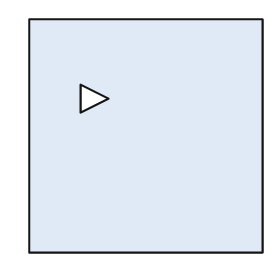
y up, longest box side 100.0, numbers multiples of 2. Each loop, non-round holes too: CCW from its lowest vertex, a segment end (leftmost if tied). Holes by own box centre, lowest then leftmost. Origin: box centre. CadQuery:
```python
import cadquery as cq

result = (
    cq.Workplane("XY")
    .moveTo(-50.0, -50.0)
    .lineTo(50.0, -50.0)
    .lineTo(50.0, 50.0)
    .lineTo(-50.0, 50.0)
    .close()
    .moveTo(-28.0, 10.0)
    .lineTo(-16.0, 16.0)
    .lineTo(-28.0, 22.0)
    .close()
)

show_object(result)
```